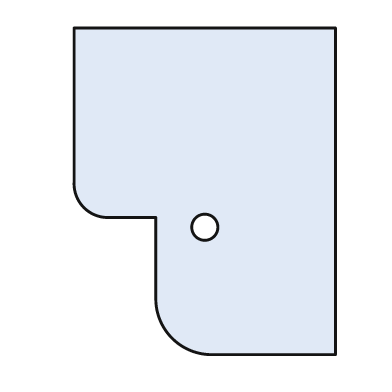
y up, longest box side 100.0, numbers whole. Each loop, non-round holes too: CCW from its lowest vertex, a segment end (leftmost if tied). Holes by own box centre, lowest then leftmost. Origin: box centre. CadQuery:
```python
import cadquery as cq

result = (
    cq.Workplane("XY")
    .moveTo(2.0, -50.0)
    .lineTo(40.0, -50.0)
    .lineTo(40.0, 50.0)
    .lineTo(-40.0, 50.0)
    .lineTo(-40.0, 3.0)
    .threePointArc((-37.0, -5.0), (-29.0, -8.0))
    .lineTo(-15.0, -8.0)
    .lineTo(-15.0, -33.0)
    .threePointArc((-10.0, -45.0), (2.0, -50.0))
    .close()
    .moveTo(0.0, -11.0)
    .circle(4.0)
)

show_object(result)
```